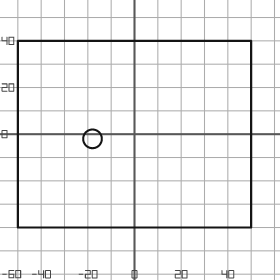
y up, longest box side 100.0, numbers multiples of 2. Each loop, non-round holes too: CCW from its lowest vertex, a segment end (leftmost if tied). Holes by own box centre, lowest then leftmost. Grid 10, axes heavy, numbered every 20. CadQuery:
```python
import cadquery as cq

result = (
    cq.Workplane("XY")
    .moveTo(-50.0, -40.0)
    .lineTo(50.0, -40.0)
    .lineTo(50.0, 40.0)
    .lineTo(-50.0, 40.0)
    .close()
    .moveTo(-18.0, -2.0)
    .circle(4.0)
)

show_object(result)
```